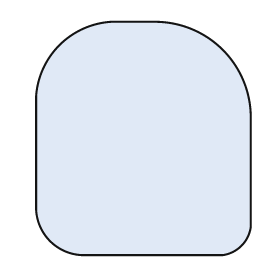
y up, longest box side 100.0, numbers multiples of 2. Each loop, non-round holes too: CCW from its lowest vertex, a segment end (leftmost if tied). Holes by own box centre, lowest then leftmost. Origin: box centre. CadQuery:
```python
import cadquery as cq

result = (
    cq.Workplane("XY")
    .moveTo(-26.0, -50.0)
    .lineTo(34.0, -50.0)
    .threePointArc((42.0, -46.0), (46.0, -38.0))
    .lineTo(46.0, 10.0)
    .threePointArc((34.0, 38.0), (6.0, 50.0))
    .lineTo(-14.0, 50.0)
    .threePointArc((-36.0, 40.0), (-46.0, 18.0))
    .lineTo(-46.0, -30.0)
    .threePointArc((-40.0, -44.0), (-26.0, -50.0))
    .close()
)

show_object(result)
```